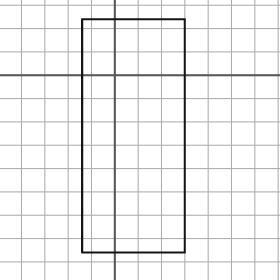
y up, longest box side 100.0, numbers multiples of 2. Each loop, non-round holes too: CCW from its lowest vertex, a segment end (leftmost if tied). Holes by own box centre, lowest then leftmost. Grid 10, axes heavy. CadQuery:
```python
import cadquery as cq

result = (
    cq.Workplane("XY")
    .moveTo(-14.0, -76.0)
    .lineTo(30.0, -76.0)
    .lineTo(30.0, 24.0)
    .lineTo(-14.0, 24.0)
    .close()
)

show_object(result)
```